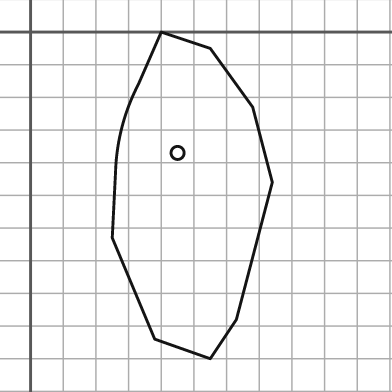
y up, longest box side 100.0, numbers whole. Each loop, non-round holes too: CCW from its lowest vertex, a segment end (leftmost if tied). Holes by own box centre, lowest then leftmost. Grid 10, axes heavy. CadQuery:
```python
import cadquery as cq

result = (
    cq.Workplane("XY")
    .moveTo(55.0, -100.0)
    .lineTo(63.0, -88.0)
    .lineTo(74.0, -46.0)
    .lineTo(68.0, -23.0)
    .lineTo(55.0, -5.0)
    .lineTo(40.0, 0.0)
    .lineTo(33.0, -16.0)
    .threePointArc((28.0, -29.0), (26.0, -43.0))
    .lineTo(25.0, -63.0)
    .lineTo(38.0, -94.0)
    .close()
    .moveTo(45.0, -37.0)
    .circle(2.0)
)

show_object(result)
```